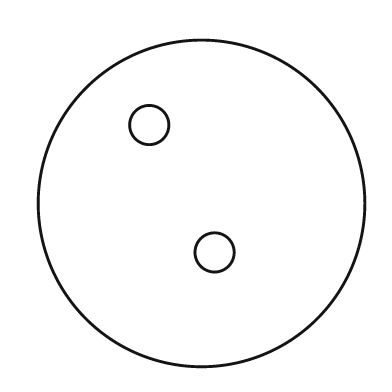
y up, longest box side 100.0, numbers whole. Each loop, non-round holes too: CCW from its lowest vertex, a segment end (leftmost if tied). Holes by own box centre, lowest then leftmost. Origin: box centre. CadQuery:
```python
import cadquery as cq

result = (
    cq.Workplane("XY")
    .moveTo(0.0, 0.0)
    .circle(50.0)
    .moveTo(4.0, -15.0)
    .circle(6.0)
    .moveTo(-16.0, 24.0)
    .circle(6.0)
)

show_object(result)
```